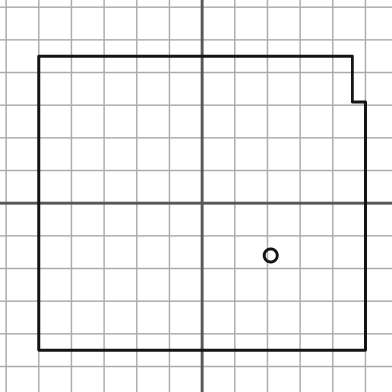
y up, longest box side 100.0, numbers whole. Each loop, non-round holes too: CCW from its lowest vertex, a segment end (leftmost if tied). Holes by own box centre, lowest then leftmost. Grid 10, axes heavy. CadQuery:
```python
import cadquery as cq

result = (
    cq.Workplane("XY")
    .moveTo(-50.0, -45.0)
    .lineTo(50.0, -45.0)
    .lineTo(50.0, 31.0)
    .lineTo(46.0, 31.0)
    .lineTo(46.0, 45.0)
    .lineTo(-50.0, 45.0)
    .close()
    .moveTo(21.0, -16.0)
    .circle(2.0)
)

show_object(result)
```